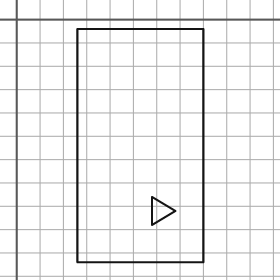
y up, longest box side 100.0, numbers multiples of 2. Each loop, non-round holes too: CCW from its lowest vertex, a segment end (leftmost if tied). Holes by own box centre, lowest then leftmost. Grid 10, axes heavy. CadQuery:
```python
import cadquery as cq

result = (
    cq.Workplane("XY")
    .moveTo(26.0, -104.0)
    .lineTo(80.0, -104.0)
    .lineTo(80.0, -4.0)
    .lineTo(26.0, -4.0)
    .close()
    .moveTo(58.0, -88.0)
    .lineTo(68.0, -82.0)
    .lineTo(58.0, -76.0)
    .close()
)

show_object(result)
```